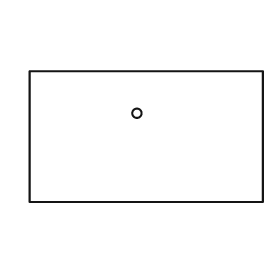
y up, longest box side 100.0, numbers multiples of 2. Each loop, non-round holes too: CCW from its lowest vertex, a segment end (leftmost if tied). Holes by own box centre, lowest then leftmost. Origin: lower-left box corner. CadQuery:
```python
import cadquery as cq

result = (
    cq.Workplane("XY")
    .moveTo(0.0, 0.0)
    .lineTo(100.0, 0.0)
    .lineTo(100.0, 56.0)
    .lineTo(0.0, 56.0)
    .close()
    .moveTo(46.0, 38.0)
    .circle(2.0)
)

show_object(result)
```